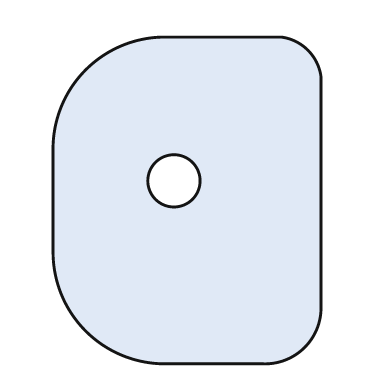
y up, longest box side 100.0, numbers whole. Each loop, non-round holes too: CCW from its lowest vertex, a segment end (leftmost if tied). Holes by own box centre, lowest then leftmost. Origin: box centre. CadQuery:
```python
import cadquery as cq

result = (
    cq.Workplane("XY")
    .moveTo(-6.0, -50.0)
    .lineTo(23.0, -50.0)
    .threePointArc((36.0, -45.0), (41.0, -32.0))
    .lineTo(41.0, 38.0)
    .threePointArc((37.0, 46.0), (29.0, 50.0))
    .lineTo(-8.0, 50.0)
    .threePointArc((-31.0, 40.0), (-41.0, 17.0))
    .lineTo(-41.0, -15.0)
    .threePointArc((-31.0, -40.0), (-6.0, -50.0))
    .close()
    .moveTo(-4.0, 6.0)
    .circle(8.0)
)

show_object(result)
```